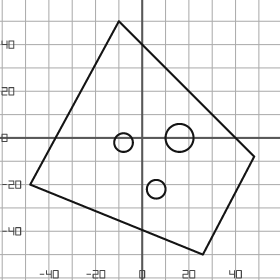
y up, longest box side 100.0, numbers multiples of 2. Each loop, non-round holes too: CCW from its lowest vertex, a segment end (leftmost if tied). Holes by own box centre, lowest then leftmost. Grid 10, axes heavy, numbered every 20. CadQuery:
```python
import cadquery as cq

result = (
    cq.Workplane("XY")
    .moveTo(26.0, -50.0)
    .lineTo(48.0, -8.0)
    .lineTo(-10.0, 50.0)
    .lineTo(-48.0, -20.0)
    .close()
    .moveTo(6.0, -22.0)
    .circle(4.0)
    .moveTo(-8.0, -2.0)
    .circle(4.0)
    .moveTo(16.0, 0.0)
    .circle(6.0)
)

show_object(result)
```